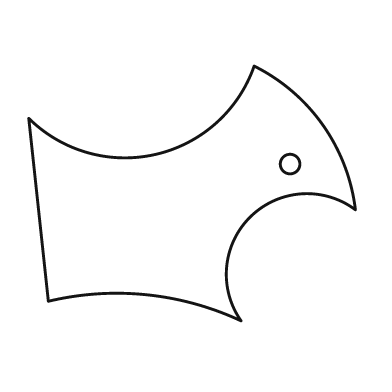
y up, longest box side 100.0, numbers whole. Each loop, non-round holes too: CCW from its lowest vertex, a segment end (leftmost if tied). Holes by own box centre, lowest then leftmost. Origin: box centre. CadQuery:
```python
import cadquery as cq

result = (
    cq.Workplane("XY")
    .moveTo(15.0, -39.0)
    .threePointArc((18.0, -7.0), (50.0, -5.0))
    .threePointArc((40.0, 21.0), (19.0, 39.0))
    .threePointArc((-11.0, 12.0), (-50.0, 23.0))
    .lineTo(-44.0, -33.0)
    .threePointArc((-14.0, -31.0), (15.0, -39.0))
    .close()
    .moveTo(30.0, 9.0)
    .circle(3.0)
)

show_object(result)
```